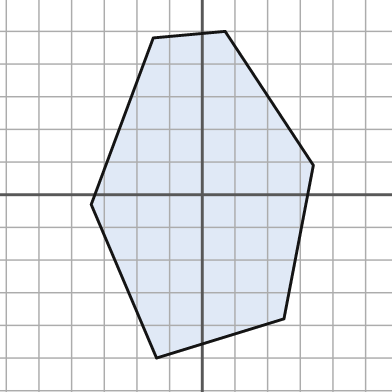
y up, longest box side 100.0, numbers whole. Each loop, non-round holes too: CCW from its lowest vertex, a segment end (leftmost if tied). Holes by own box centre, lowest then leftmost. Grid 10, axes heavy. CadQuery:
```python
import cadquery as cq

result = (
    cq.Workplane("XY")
    .moveTo(-14.0, -50.0)
    .lineTo(25.0, -38.0)
    .lineTo(34.0, 9.0)
    .lineTo(7.0, 50.0)
    .lineTo(-15.0, 48.0)
    .lineTo(-34.0, -3.0)
    .close()
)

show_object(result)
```